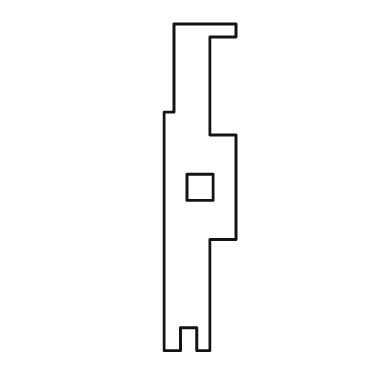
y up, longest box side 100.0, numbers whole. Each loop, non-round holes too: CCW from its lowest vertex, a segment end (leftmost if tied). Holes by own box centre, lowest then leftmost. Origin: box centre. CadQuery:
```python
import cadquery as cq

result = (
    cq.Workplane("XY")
    .moveTo(-11.0, -50.0)
    .lineTo(-6.0, -50.0)
    .lineTo(-6.0, -43.0)
    .lineTo(-1.0, -43.0)
    .lineTo(-1.0, -50.0)
    .lineTo(3.0, -50.0)
    .lineTo(3.0, -16.0)
    .lineTo(11.0, -16.0)
    .lineTo(11.0, 16.0)
    .lineTo(3.0, 16.0)
    .lineTo(3.0, 46.0)
    .lineTo(11.0, 46.0)
    .lineTo(11.0, 50.0)
    .lineTo(-8.0, 50.0)
    .lineTo(-8.0, 23.0)
    .lineTo(-11.0, 23.0)
    .close()
    .moveTo(-4.0, -4.0)
    .lineTo(4.0, -4.0)
    .lineTo(4.0, 4.0)
    .lineTo(-4.0, 4.0)
    .close()
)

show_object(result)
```